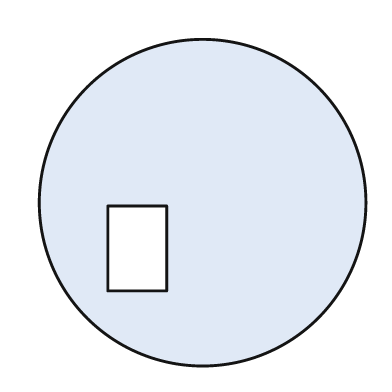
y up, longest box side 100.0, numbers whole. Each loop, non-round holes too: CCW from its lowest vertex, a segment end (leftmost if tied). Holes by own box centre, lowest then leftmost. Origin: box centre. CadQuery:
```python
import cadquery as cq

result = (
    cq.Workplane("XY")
    .moveTo(0.0, 0.0)
    .circle(50.0)
    .moveTo(-29.0, -27.0)
    .lineTo(-11.0, -27.0)
    .lineTo(-11.0, -1.0)
    .lineTo(-29.0, -1.0)
    .close()
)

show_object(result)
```